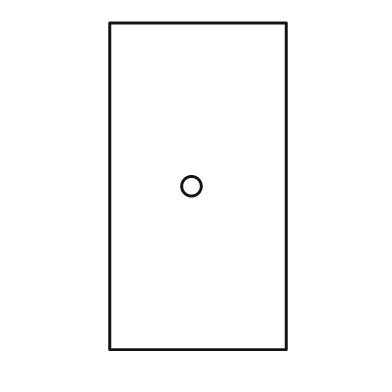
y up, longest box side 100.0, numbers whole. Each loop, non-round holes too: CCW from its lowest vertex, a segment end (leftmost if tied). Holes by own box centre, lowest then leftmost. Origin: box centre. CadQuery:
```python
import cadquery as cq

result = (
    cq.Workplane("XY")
    .moveTo(-27.0, -50.0)
    .lineTo(27.0, -50.0)
    .lineTo(27.0, 50.0)
    .lineTo(-27.0, 50.0)
    .close()
    .moveTo(-2.0, 0.0)
    .circle(3.0)
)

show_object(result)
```